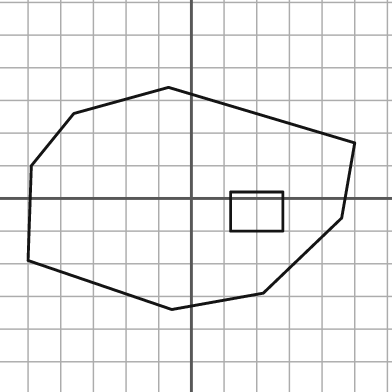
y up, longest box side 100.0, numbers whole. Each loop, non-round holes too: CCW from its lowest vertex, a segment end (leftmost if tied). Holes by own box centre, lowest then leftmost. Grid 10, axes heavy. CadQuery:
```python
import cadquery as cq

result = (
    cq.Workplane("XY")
    .moveTo(-6.0, -34.0)
    .lineTo(22.0, -29.0)
    .lineTo(46.0, -6.0)
    .lineTo(50.0, 17.0)
    .lineTo(-7.0, 34.0)
    .lineTo(-36.0, 26.0)
    .lineTo(-49.0, 10.0)
    .lineTo(-50.0, -19.0)
    .close()
    .moveTo(12.0, -10.0)
    .lineTo(28.0, -10.0)
    .lineTo(28.0, 2.0)
    .lineTo(12.0, 2.0)
    .close()
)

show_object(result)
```